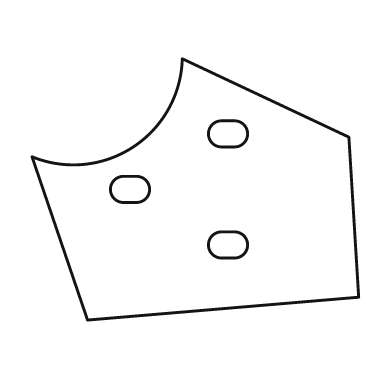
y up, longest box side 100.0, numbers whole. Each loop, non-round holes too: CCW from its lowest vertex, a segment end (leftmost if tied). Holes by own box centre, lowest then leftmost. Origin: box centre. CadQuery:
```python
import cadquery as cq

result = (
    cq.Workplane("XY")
    .moveTo(-33.0, -40.0)
    .lineTo(50.0, -33.0)
    .lineTo(47.0, 16.0)
    .lineTo(-4.0, 40.0)
    .threePointArc((-19.0, 13.0), (-50.0, 10.0))
    .close()
    .moveTo(8.0, -21.0)
    .lineTo(12.0, -21.0)
    .threePointArc((16.0, -17.0), (12.0, -13.0))
    .lineTo(8.0, -13.0)
    .threePointArc((4.0, -17.0), (8.0, -21.0))
    .close()
    .moveTo(-22.0, -4.0)
    .lineTo(-18.0, -4.0)
    .threePointArc((-14.0, 0.0), (-18.0, 4.0))
    .lineTo(-22.0, 4.0)
    .threePointArc((-26.0, 0.0), (-22.0, -4.0))
    .close()
    .moveTo(8.0, 13.0)
    .lineTo(12.0, 13.0)
    .threePointArc((16.0, 17.0), (12.0, 21.0))
    .lineTo(8.0, 21.0)
    .threePointArc((4.0, 17.0), (8.0, 13.0))
    .close()
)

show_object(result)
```